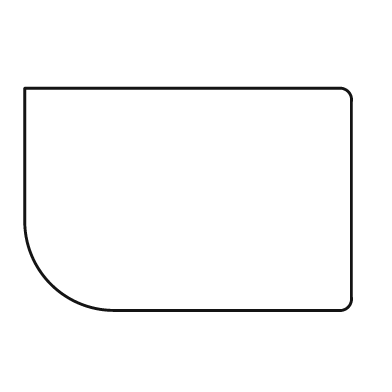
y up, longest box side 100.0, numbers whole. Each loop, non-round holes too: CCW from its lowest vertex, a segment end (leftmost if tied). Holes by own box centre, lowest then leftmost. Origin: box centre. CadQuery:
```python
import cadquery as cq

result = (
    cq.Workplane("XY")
    .moveTo(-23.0, -34.0)
    .lineTo(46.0, -34.0)
    .threePointArc((49.0, -33.0), (50.0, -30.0))
    .lineTo(50.0, 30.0)
    .threePointArc((49.0, 33.0), (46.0, 34.0))
    .lineTo(-50.0, 34.0)
    .lineTo(-50.0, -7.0)
    .threePointArc((-42.0, -26.0), (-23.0, -34.0))
    .close()
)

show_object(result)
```